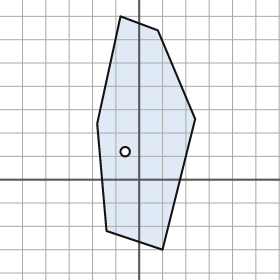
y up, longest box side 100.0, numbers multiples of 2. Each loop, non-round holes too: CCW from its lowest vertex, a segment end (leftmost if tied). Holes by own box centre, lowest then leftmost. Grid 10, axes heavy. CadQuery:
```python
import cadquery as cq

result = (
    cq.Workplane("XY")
    .moveTo(10.0, -30.0)
    .lineTo(24.0, 26.0)
    .lineTo(8.0, 64.0)
    .lineTo(-8.0, 70.0)
    .lineTo(-18.0, 24.0)
    .lineTo(-14.0, -22.0)
    .close()
    .moveTo(-6.0, 12.0)
    .circle(2.0)
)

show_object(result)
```